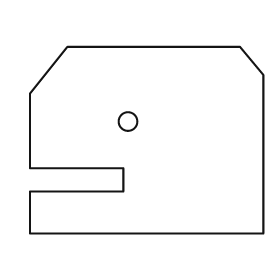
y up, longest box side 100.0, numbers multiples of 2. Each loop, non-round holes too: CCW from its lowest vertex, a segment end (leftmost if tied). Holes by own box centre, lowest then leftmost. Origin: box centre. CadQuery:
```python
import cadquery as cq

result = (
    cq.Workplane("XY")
    .moveTo(-50.0, -40.0)
    .lineTo(50.0, -40.0)
    .lineTo(50.0, 28.0)
    .lineTo(40.0, 40.0)
    .lineTo(-34.0, 40.0)
    .lineTo(-50.0, 20.0)
    .lineTo(-50.0, -12.0)
    .lineTo(-10.0, -12.0)
    .lineTo(-10.0, -22.0)
    .lineTo(-50.0, -22.0)
    .close()
    .moveTo(-8.0, 8.0)
    .circle(4.0)
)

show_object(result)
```